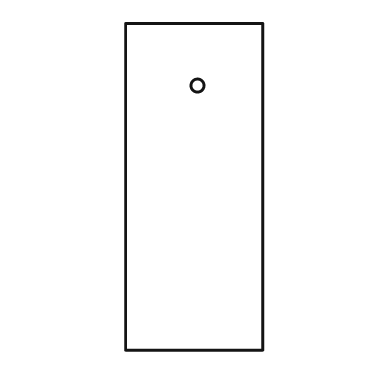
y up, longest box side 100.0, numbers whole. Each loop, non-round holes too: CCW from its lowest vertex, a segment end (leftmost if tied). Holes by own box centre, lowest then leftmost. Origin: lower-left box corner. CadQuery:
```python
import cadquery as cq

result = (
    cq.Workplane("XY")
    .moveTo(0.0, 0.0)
    .lineTo(42.0, 0.0)
    .lineTo(42.0, 100.0)
    .lineTo(0.0, 100.0)
    .close()
    .moveTo(22.0, 81.0)
    .circle(2.0)
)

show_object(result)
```